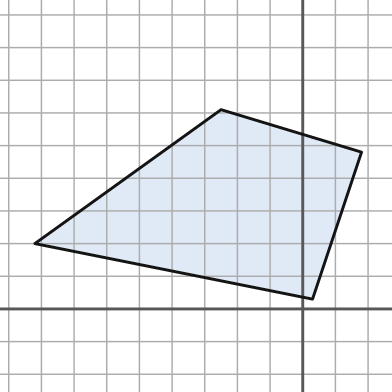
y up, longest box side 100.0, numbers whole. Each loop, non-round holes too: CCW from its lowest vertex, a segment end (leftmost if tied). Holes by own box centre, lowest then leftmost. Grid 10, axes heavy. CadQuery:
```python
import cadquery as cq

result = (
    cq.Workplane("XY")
    .moveTo(3.0, 3.0)
    .lineTo(18.0, 48.0)
    .lineTo(-25.0, 61.0)
    .lineTo(-82.0, 20.0)
    .close()
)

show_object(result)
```